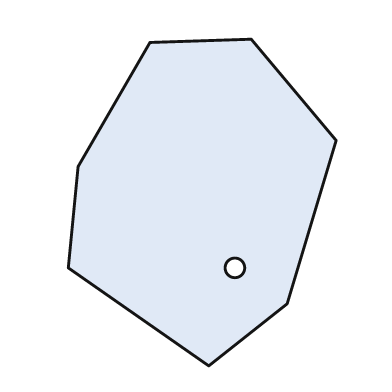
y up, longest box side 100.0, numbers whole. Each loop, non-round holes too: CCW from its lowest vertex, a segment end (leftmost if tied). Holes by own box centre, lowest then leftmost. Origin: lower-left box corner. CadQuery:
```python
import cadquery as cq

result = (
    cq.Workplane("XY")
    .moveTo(43.0, 0.0)
    .lineTo(67.0, 19.0)
    .lineTo(82.0, 69.0)
    .lineTo(56.0, 100.0)
    .lineTo(25.0, 99.0)
    .lineTo(3.0, 61.0)
    .lineTo(0.0, 30.0)
    .close()
    .moveTo(51.0, 30.0)
    .circle(3.0)
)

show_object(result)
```